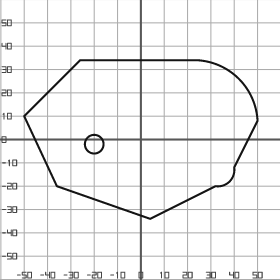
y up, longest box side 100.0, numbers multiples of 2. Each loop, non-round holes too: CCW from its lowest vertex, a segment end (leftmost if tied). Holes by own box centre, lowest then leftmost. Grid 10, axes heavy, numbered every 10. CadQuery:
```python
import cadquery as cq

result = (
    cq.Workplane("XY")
    .moveTo(4.0, -34.0)
    .lineTo(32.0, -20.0)
    .threePointArc((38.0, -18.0), (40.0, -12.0))
    .lineTo(50.0, 8.0)
    .threePointArc((42.0, 26.0), (24.0, 34.0))
    .lineTo(-26.0, 34.0)
    .lineTo(-50.0, 10.0)
    .lineTo(-36.0, -20.0)
    .close()
    .moveTo(-20.0, -2.0)
    .circle(4.0)
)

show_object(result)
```